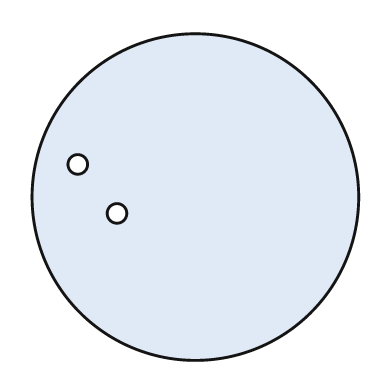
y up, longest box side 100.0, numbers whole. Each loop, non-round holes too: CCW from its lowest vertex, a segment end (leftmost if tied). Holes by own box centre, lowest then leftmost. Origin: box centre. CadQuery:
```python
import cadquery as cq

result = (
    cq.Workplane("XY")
    .moveTo(0.0, 0.0)
    .circle(50.0)
    .moveTo(-24.0, -5.0)
    .circle(3.0)
    .moveTo(-36.0, 10.0)
    .circle(3.0)
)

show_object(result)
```